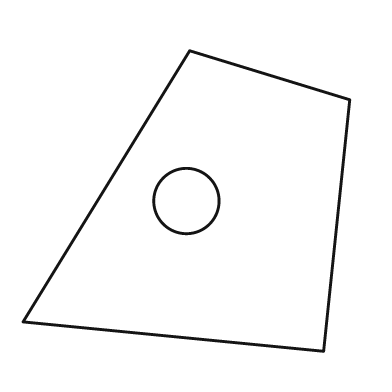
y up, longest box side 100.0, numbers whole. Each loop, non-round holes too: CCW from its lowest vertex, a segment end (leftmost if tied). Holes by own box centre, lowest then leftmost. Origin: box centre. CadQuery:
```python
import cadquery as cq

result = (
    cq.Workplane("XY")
    .moveTo(42.0, -46.0)
    .lineTo(50.0, 31.0)
    .lineTo(1.0, 46.0)
    .lineTo(-50.0, -37.0)
    .close()
    .moveTo(0.0, 0.0)
    .circle(10.0)
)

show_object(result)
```